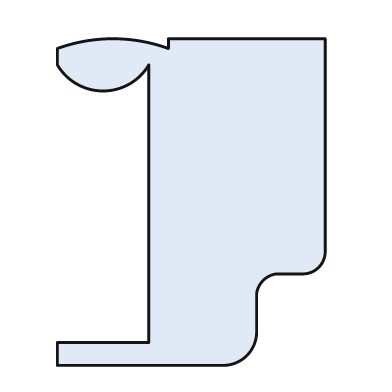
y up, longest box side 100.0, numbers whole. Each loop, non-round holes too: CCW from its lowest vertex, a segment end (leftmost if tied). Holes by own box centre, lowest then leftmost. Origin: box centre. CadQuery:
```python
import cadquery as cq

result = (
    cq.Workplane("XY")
    .moveTo(-41.0, -50.0)
    .lineTo(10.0, -50.0)
    .threePointArc((17.0, -47.0), (20.0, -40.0))
    .lineTo(20.0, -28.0)
    .threePointArc((22.0, -24.0), (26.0, -22.0))
    .lineTo(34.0, -22.0)
    .threePointArc((39.0, -20.0), (41.0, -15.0))
    .lineTo(41.0, 50.0)
    .lineTo(-7.0, 50.0)
    .lineTo(-7.0, 47.0)
    .threePointArc((-24.0, 50.0), (-41.0, 47.0))
    .lineTo(-41.0, 42.0)
    .threePointArc((-27.0, 34.0), (-13.0, 42.0))
    .lineTo(-13.0, -43.0)
    .lineTo(-41.0, -43.0)
    .close()
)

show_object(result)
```